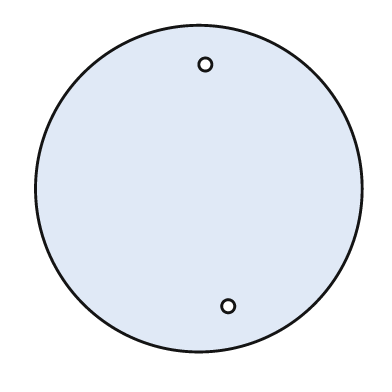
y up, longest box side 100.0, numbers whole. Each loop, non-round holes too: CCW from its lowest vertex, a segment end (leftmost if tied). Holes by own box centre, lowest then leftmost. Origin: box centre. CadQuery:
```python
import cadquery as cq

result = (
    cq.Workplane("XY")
    .moveTo(0.0, 0.0)
    .circle(50.0)
    .moveTo(9.0, -36.0)
    .circle(2.0)
    .moveTo(2.0, 38.0)
    .circle(2.0)
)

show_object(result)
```